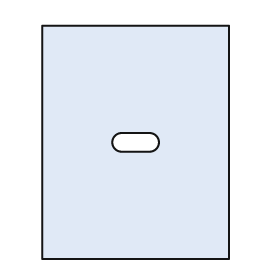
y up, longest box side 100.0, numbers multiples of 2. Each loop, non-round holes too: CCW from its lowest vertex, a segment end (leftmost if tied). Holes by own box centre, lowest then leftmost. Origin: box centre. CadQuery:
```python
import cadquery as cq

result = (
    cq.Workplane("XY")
    .moveTo(-40.0, -50.0)
    .lineTo(40.0, -50.0)
    .lineTo(40.0, 50.0)
    .lineTo(-40.0, 50.0)
    .close()
    .moveTo(-6.0, -4.0)
    .lineTo(6.0, -4.0)
    .threePointArc((10.0, 0.0), (6.0, 4.0))
    .lineTo(-6.0, 4.0)
    .threePointArc((-10.0, 0.0), (-6.0, -4.0))
    .close()
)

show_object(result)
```